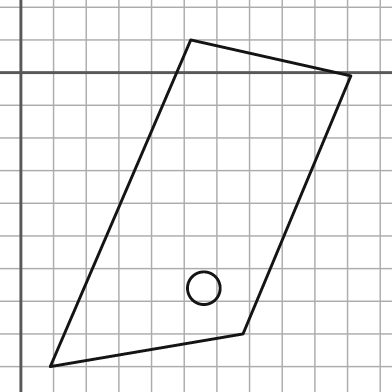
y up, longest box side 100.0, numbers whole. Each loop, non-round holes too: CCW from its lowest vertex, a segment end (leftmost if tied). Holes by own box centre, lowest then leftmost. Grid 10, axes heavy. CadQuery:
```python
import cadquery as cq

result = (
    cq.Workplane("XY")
    .moveTo(9.0, -90.0)
    .lineTo(68.0, -80.0)
    .lineTo(101.0, -1.0)
    .lineTo(52.0, 10.0)
    .close()
    .moveTo(56.0, -66.0)
    .circle(5.0)
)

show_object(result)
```